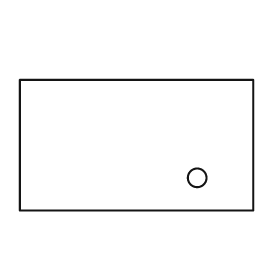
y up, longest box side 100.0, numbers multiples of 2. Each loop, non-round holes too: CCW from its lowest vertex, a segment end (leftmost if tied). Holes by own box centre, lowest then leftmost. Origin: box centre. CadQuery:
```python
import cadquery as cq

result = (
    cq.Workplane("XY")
    .moveTo(-50.0, -28.0)
    .lineTo(50.0, -28.0)
    .lineTo(50.0, 28.0)
    .lineTo(-50.0, 28.0)
    .close()
    .moveTo(26.0, -14.0)
    .circle(4.0)
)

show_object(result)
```